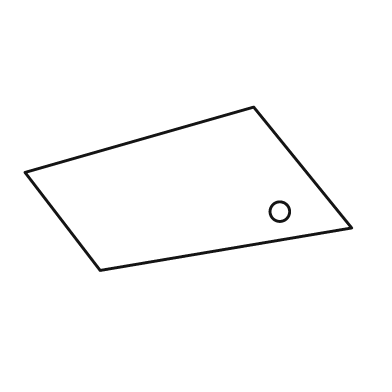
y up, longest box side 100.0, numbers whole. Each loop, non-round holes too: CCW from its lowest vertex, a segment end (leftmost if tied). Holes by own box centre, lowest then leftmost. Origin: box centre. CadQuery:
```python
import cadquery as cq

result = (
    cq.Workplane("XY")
    .moveTo(-27.0, -25.0)
    .lineTo(50.0, -12.0)
    .lineTo(20.0, 25.0)
    .lineTo(-50.0, 5.0)
    .close()
    .moveTo(28.0, -7.0)
    .circle(3.0)
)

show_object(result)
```